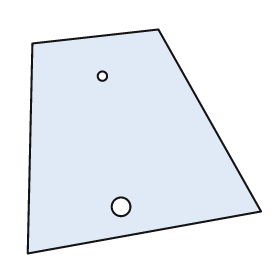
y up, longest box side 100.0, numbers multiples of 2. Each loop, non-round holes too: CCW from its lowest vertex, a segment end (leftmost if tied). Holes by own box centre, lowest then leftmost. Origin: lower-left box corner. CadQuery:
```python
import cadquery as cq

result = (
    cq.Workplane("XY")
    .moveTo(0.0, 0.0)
    .lineTo(100.0, 18.0)
    .lineTo(56.0, 96.0)
    .lineTo(2.0, 90.0)
    .close()
    .moveTo(40.0, 20.0)
    .circle(4.0)
    .moveTo(32.0, 76.0)
    .circle(2.0)
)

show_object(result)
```